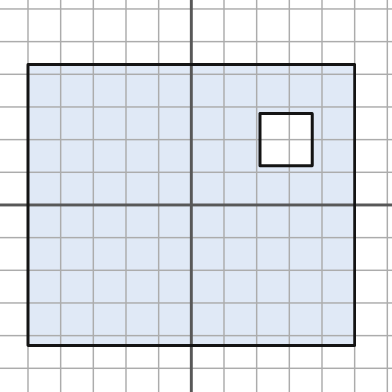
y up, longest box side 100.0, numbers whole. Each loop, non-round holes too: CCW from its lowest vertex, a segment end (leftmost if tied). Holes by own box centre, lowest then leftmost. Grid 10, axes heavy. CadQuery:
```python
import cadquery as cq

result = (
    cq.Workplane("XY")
    .moveTo(-50.0, -43.0)
    .lineTo(50.0, -43.0)
    .lineTo(50.0, 43.0)
    .lineTo(-50.0, 43.0)
    .close()
    .moveTo(21.0, 12.0)
    .lineTo(37.0, 12.0)
    .lineTo(37.0, 28.0)
    .lineTo(21.0, 28.0)
    .close()
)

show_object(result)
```